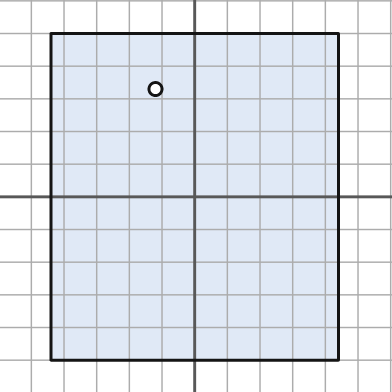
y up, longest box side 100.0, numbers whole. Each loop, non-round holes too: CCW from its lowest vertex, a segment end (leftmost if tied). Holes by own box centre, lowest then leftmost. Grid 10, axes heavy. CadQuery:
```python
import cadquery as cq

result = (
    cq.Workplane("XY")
    .moveTo(-44.0, -50.0)
    .lineTo(44.0, -50.0)
    .lineTo(44.0, 50.0)
    .lineTo(-44.0, 50.0)
    .close()
    .moveTo(-12.0, 33.0)
    .circle(2.0)
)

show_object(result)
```